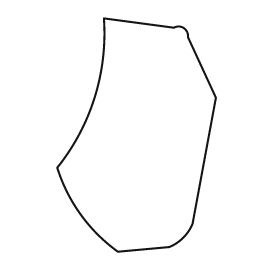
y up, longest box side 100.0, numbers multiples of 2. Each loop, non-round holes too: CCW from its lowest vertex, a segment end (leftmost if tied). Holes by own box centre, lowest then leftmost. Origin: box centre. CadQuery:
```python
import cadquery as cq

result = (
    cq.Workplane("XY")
    .moveTo(-8.0, -50.0)
    .lineTo(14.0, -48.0)
    .threePointArc((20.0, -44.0), (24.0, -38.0))
    .lineTo(34.0, 16.0)
    .lineTo(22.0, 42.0)
    .threePointArc((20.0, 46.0), (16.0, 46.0))
    .lineTo(-14.0, 50.0)
    .threePointArc((-18.0, 16.0), (-34.0, -14.0))
    .threePointArc((-24.0, -34.0), (-8.0, -50.0))
    .close()
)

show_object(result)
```